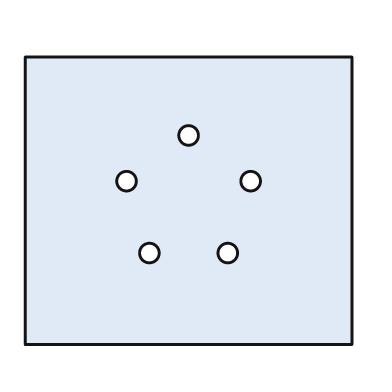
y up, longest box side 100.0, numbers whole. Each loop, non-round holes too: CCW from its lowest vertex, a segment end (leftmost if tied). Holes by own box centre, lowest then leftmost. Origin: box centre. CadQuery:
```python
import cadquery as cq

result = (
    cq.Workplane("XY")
    .moveTo(-50.0, -44.0)
    .lineTo(50.0, -44.0)
    .lineTo(50.0, 44.0)
    .lineTo(-50.0, 44.0)
    .close()
    .moveTo(-12.0, -16.0)
    .circle(3.0)
    .moveTo(12.0, -16.0)
    .circle(3.0)
    .moveTo(-19.0, 6.0)
    .circle(3.0)
    .moveTo(19.0, 6.0)
    .circle(3.0)
    .moveTo(0.0, 20.0)
    .circle(3.0)
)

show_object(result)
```